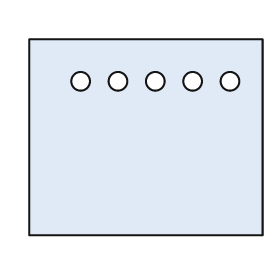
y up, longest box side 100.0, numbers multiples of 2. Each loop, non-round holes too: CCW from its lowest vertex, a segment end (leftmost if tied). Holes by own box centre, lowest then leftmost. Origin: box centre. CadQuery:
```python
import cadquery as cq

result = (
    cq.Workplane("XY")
    .moveTo(-50.0, -42.0)
    .lineTo(50.0, -42.0)
    .lineTo(50.0, 42.0)
    .lineTo(-50.0, 42.0)
    .close()
    .moveTo(-28.0, 24.0)
    .circle(4.0)
    .moveTo(-12.0, 24.0)
    .circle(4.0)
    .moveTo(4.0, 24.0)
    .circle(4.0)
    .moveTo(20.0, 24.0)
    .circle(4.0)
    .moveTo(36.0, 24.0)
    .circle(4.0)
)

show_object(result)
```